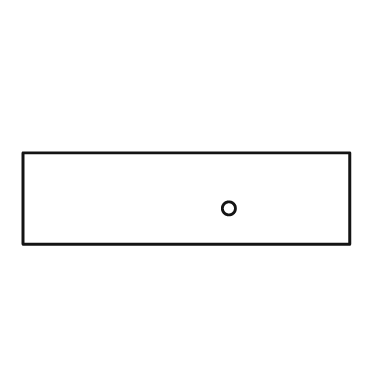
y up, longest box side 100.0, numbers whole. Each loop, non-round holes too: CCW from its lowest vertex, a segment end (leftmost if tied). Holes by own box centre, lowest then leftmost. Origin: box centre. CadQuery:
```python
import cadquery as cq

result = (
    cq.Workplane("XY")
    .moveTo(-50.0, -14.0)
    .lineTo(50.0, -14.0)
    .lineTo(50.0, 14.0)
    .lineTo(-50.0, 14.0)
    .close()
    .moveTo(13.0, -3.0)
    .circle(2.0)
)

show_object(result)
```